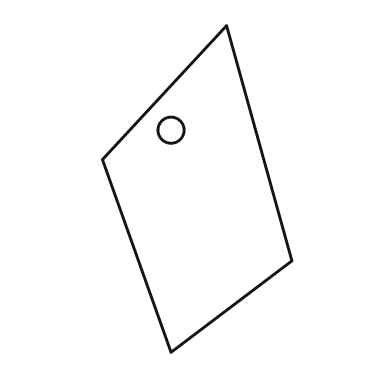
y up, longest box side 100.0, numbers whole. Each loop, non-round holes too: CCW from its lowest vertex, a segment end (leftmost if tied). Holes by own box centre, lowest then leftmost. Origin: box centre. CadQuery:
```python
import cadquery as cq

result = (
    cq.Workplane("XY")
    .moveTo(-8.0, -50.0)
    .lineTo(29.0, -22.0)
    .lineTo(9.0, 50.0)
    .lineTo(-29.0, 9.0)
    .close()
    .moveTo(-8.0, 18.0)
    .circle(4.0)
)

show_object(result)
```